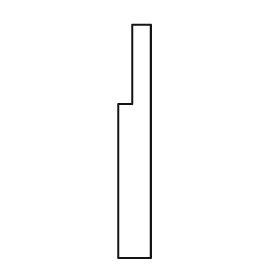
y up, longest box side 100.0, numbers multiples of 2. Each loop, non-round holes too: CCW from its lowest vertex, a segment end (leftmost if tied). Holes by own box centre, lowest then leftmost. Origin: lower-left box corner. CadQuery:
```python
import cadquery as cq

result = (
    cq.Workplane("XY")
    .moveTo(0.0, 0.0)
    .lineTo(14.0, 0.0)
    .lineTo(14.0, 100.0)
    .lineTo(6.0, 100.0)
    .lineTo(6.0, 66.0)
    .lineTo(0.0, 66.0)
    .close()
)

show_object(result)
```